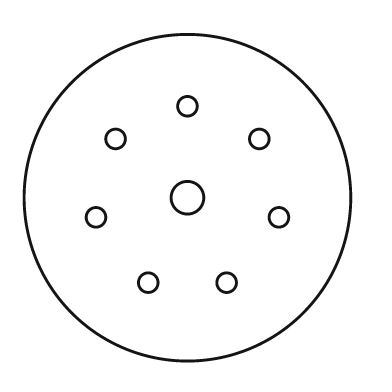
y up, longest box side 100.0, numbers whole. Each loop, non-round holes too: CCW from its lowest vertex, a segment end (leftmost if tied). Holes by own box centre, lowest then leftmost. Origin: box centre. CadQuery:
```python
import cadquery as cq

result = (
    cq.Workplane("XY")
    .moveTo(0.0, 0.0)
    .circle(50.0)
    .moveTo(-12.0, -26.0)
    .circle(3.0)
    .moveTo(12.0, -26.0)
    .circle(3.0)
    .moveTo(-28.0, -6.0)
    .circle(3.0)
    .moveTo(28.0, -6.0)
    .circle(3.0)
    .moveTo(0.0, 0.0)
    .circle(5.0)
    .moveTo(-22.0, 18.0)
    .circle(3.0)
    .moveTo(22.0, 18.0)
    .circle(3.0)
    .moveTo(0.0, 28.0)
    .circle(3.0)
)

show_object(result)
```